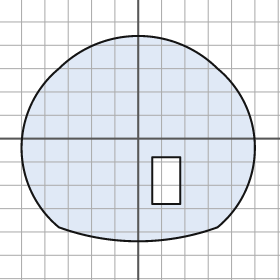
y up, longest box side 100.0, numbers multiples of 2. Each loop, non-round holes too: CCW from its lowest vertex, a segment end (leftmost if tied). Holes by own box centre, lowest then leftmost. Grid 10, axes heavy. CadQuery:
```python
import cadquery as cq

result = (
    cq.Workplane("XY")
    .moveTo(-34.0, -38.0)
    .threePointArc((0.0, -44.0), (34.0, -38.0))
    .threePointArc((50.0, -4.0), (34.0, 30.0))
    .threePointArc((0.0, 44.0), (-34.0, 30.0))
    .threePointArc((-50.0, -4.0), (-34.0, -38.0))
    .close()
    .moveTo(6.0, -28.0)
    .lineTo(18.0, -28.0)
    .lineTo(18.0, -8.0)
    .lineTo(6.0, -8.0)
    .close()
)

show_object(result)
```